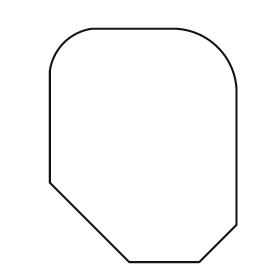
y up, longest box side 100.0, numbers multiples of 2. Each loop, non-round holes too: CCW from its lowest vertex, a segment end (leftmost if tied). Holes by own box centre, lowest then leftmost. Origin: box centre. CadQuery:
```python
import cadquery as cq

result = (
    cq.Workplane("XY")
    .moveTo(-6.0, -50.0)
    .lineTo(24.0, -50.0)
    .lineTo(40.0, -34.0)
    .lineTo(40.0, 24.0)
    .threePointArc((32.0, 42.0), (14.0, 50.0))
    .lineTo(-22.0, 50.0)
    .threePointArc((-34.0, 44.0), (-40.0, 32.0))
    .lineTo(-40.0, -16.0)
    .close()
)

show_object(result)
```